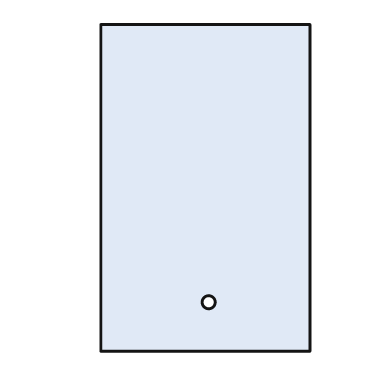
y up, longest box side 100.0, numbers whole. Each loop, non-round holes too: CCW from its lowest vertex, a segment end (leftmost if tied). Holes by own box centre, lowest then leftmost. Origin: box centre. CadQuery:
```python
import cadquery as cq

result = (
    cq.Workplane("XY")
    .moveTo(-32.0, -50.0)
    .lineTo(32.0, -50.0)
    .lineTo(32.0, 50.0)
    .lineTo(-32.0, 50.0)
    .close()
    .moveTo(1.0, -35.0)
    .circle(2.0)
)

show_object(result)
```